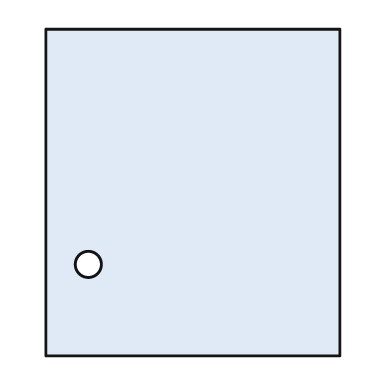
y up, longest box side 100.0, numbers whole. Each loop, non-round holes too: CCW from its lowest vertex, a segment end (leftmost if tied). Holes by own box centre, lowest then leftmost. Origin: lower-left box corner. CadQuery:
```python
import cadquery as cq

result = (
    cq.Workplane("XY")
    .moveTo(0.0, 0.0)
    .lineTo(90.0, 0.0)
    .lineTo(90.0, 100.0)
    .lineTo(0.0, 100.0)
    .close()
    .moveTo(13.0, 28.0)
    .circle(4.0)
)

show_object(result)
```